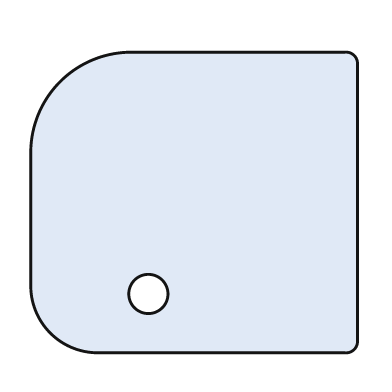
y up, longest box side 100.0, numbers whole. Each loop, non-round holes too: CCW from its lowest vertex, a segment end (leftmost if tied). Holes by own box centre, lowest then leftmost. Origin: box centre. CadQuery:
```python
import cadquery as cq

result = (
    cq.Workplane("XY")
    .moveTo(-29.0, -46.0)
    .lineTo(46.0, -46.0)
    .threePointArc((49.0, -45.0), (50.0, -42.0))
    .lineTo(50.0, 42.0)
    .threePointArc((49.0, 45.0), (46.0, 46.0))
    .lineTo(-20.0, 46.0)
    .threePointArc((-41.0, 37.0), (-50.0, 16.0))
    .lineTo(-50.0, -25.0)
    .threePointArc((-44.0, -40.0), (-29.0, -46.0))
    .close()
    .moveTo(-14.0, -28.0)
    .circle(6.0)
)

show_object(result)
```